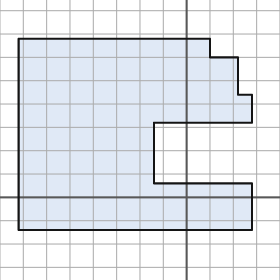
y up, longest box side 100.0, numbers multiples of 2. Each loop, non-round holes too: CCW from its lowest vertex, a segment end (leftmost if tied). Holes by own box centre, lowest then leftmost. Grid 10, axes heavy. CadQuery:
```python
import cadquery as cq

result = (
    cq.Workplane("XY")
    .moveTo(-72.0, -14.0)
    .lineTo(28.0, -14.0)
    .lineTo(28.0, 6.0)
    .lineTo(-14.0, 6.0)
    .lineTo(-14.0, 32.0)
    .lineTo(28.0, 32.0)
    .lineTo(28.0, 44.0)
    .lineTo(22.0, 44.0)
    .lineTo(22.0, 60.0)
    .lineTo(10.0, 60.0)
    .lineTo(10.0, 68.0)
    .lineTo(-72.0, 68.0)
    .close()
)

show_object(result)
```